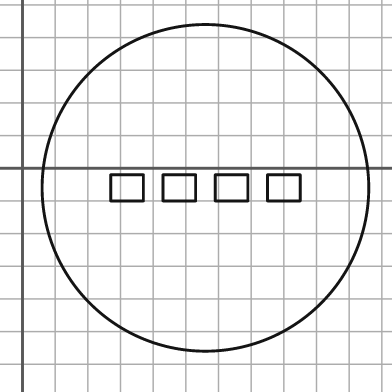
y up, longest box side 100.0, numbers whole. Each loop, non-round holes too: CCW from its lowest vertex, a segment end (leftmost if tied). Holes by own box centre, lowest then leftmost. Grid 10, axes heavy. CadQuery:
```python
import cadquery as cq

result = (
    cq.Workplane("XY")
    .moveTo(56.0, -6.0)
    .circle(50.0)
    .moveTo(27.0, -10.0)
    .lineTo(37.0, -10.0)
    .lineTo(37.0, -2.0)
    .lineTo(27.0, -2.0)
    .close()
    .moveTo(43.0, -10.0)
    .lineTo(53.0, -10.0)
    .lineTo(53.0, -2.0)
    .lineTo(43.0, -2.0)
    .close()
    .moveTo(59.0, -10.0)
    .lineTo(69.0, -10.0)
    .lineTo(69.0, -2.0)
    .lineTo(59.0, -2.0)
    .close()
    .moveTo(75.0, -10.0)
    .lineTo(85.0, -10.0)
    .lineTo(85.0, -2.0)
    .lineTo(75.0, -2.0)
    .close()
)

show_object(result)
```